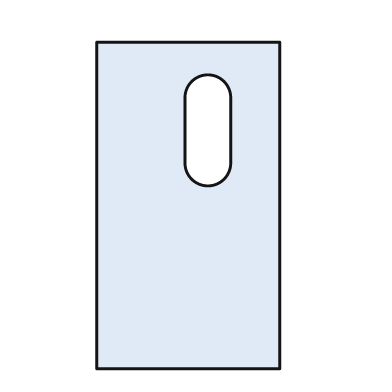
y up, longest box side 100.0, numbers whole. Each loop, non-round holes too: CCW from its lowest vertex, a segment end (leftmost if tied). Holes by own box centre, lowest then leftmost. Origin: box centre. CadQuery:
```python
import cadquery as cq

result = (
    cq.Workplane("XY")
    .moveTo(-28.0, -50.0)
    .lineTo(28.0, -50.0)
    .lineTo(28.0, 50.0)
    .lineTo(-28.0, 50.0)
    .close()
    .moveTo(-1.0, 13.0)
    .threePointArc((6.0, 6.0), (13.0, 13.0))
    .lineTo(13.0, 33.0)
    .threePointArc((6.0, 40.0), (-1.0, 33.0))
    .close()
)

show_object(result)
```